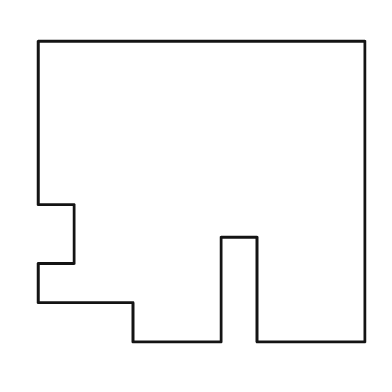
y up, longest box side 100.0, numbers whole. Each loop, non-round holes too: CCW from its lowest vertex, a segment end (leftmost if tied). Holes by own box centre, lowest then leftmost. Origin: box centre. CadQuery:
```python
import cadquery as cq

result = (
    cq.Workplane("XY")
    .moveTo(-21.0, -46.0)
    .lineTo(6.0, -46.0)
    .lineTo(6.0, -14.0)
    .lineTo(17.0, -14.0)
    .lineTo(17.0, -46.0)
    .lineTo(50.0, -46.0)
    .lineTo(50.0, 46.0)
    .lineTo(-50.0, 46.0)
    .lineTo(-50.0, -4.0)
    .lineTo(-39.0, -4.0)
    .lineTo(-39.0, -22.0)
    .lineTo(-50.0, -22.0)
    .lineTo(-50.0, -34.0)
    .lineTo(-21.0, -34.0)
    .close()
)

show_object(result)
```